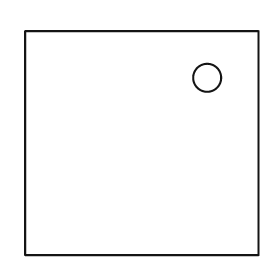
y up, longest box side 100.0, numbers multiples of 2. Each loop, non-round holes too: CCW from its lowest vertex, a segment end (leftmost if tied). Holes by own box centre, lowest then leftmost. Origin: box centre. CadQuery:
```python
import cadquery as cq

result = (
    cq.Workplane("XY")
    .moveTo(-50.0, -48.0)
    .lineTo(50.0, -48.0)
    .lineTo(50.0, 48.0)
    .lineTo(-50.0, 48.0)
    .close()
    .moveTo(28.0, 28.0)
    .circle(6.0)
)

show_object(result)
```